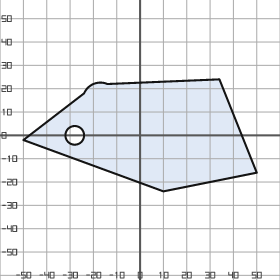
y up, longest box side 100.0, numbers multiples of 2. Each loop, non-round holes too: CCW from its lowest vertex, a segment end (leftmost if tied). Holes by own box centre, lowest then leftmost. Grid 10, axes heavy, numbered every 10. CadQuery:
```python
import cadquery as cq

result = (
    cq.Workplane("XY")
    .moveTo(10.0, -24.0)
    .lineTo(50.0, -16.0)
    .lineTo(34.0, 24.0)
    .lineTo(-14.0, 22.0)
    .threePointArc((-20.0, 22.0), (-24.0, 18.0))
    .lineTo(-50.0, -2.0)
    .close()
    .moveTo(-28.0, 0.0)
    .circle(4.0)
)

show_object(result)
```